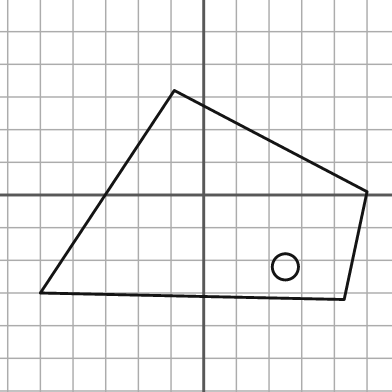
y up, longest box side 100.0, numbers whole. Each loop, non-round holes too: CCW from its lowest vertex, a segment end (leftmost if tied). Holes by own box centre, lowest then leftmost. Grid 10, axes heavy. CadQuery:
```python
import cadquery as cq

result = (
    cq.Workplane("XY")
    .moveTo(43.0, -32.0)
    .lineTo(50.0, 1.0)
    .lineTo(-9.0, 32.0)
    .lineTo(-50.0, -30.0)
    .close()
    .moveTo(25.0, -22.0)
    .circle(4.0)
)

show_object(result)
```